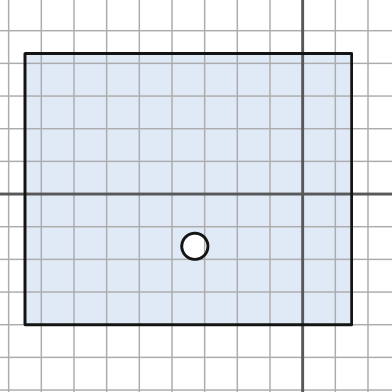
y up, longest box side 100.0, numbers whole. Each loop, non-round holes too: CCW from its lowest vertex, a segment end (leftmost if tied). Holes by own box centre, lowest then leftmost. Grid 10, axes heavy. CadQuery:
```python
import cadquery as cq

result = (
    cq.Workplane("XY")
    .moveTo(-85.0, -40.0)
    .lineTo(15.0, -40.0)
    .lineTo(15.0, 43.0)
    .lineTo(-85.0, 43.0)
    .close()
    .moveTo(-33.0, -16.0)
    .circle(4.0)
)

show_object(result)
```